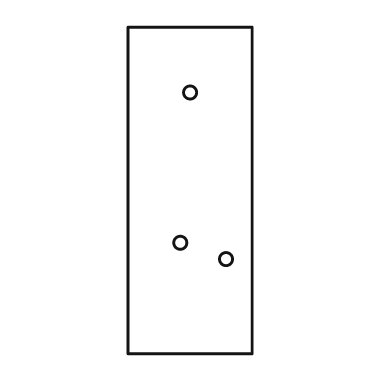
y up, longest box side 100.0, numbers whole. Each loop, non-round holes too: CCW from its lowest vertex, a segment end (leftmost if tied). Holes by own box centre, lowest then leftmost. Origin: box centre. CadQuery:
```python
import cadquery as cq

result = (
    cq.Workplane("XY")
    .moveTo(-19.0, -50.0)
    .lineTo(19.0, -50.0)
    .lineTo(19.0, 50.0)
    .lineTo(-19.0, 50.0)
    .close()
    .moveTo(11.0, -21.0)
    .circle(2.0)
    .moveTo(-3.0, -16.0)
    .circle(2.0)
    .moveTo(0.0, 30.0)
    .circle(2.0)
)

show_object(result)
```